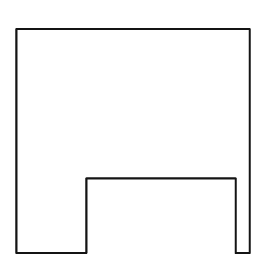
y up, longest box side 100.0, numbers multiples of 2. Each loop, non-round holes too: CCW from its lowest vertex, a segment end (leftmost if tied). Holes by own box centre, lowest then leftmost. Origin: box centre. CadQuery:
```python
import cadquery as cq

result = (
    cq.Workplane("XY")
    .moveTo(-50.0, -48.0)
    .lineTo(-20.0, -48.0)
    .lineTo(-20.0, -16.0)
    .lineTo(44.0, -16.0)
    .lineTo(44.0, -48.0)
    .lineTo(50.0, -48.0)
    .lineTo(50.0, 48.0)
    .lineTo(-50.0, 48.0)
    .close()
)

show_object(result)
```